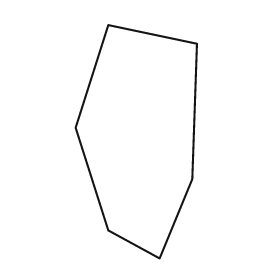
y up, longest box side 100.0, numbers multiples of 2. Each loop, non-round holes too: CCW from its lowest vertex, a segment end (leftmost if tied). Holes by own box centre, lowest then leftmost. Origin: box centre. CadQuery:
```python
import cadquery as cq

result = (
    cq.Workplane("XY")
    .moveTo(10.0, -50.0)
    .lineTo(24.0, -16.0)
    .lineTo(26.0, 42.0)
    .lineTo(-12.0, 50.0)
    .lineTo(-26.0, 6.0)
    .lineTo(-12.0, -38.0)
    .close()
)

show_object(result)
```